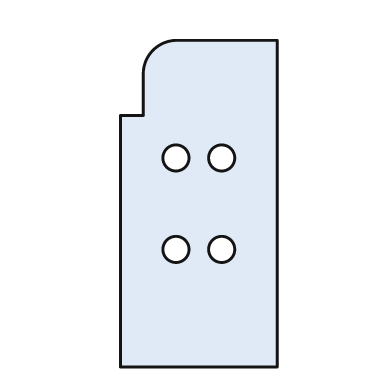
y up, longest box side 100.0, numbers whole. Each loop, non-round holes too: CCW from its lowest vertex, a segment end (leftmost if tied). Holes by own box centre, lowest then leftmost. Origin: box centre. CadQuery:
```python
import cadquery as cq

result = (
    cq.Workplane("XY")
    .moveTo(-24.0, -50.0)
    .lineTo(24.0, -50.0)
    .lineTo(24.0, 50.0)
    .lineTo(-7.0, 50.0)
    .threePointArc((-14.0, 47.0), (-17.0, 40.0))
    .lineTo(-17.0, 27.0)
    .lineTo(-24.0, 27.0)
    .close()
    .moveTo(-7.0, -14.0)
    .circle(4.0)
    .moveTo(7.0, -14.0)
    .circle(4.0)
    .moveTo(-7.0, 14.0)
    .circle(4.0)
    .moveTo(7.0, 14.0)
    .circle(4.0)
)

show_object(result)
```